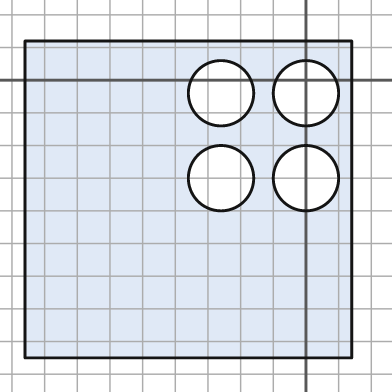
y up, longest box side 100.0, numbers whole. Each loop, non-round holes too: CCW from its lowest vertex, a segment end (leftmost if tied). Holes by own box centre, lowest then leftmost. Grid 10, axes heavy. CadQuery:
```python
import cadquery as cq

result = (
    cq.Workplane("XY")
    .moveTo(-86.0, -85.0)
    .lineTo(14.0, -85.0)
    .lineTo(14.0, 12.0)
    .lineTo(-86.0, 12.0)
    .close()
    .moveTo(-26.0, -30.0)
    .circle(10.0)
    .moveTo(0.0, -30.0)
    .circle(10.0)
    .moveTo(-26.0, -4.0)
    .circle(10.0)
    .moveTo(0.0, -4.0)
    .circle(10.0)
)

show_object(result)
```